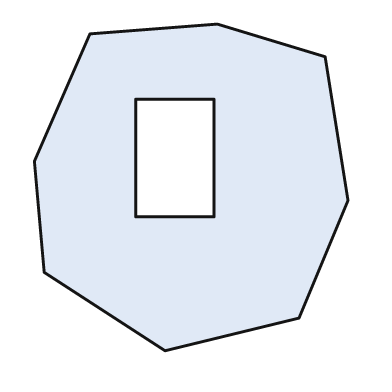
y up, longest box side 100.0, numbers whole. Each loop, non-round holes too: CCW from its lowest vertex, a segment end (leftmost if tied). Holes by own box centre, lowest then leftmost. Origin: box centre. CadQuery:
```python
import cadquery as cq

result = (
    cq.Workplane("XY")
    .moveTo(-8.0, -50.0)
    .lineTo(33.0, -40.0)
    .lineTo(48.0, -4.0)
    .lineTo(41.0, 40.0)
    .lineTo(8.0, 50.0)
    .lineTo(-31.0, 47.0)
    .lineTo(-48.0, 8.0)
    .lineTo(-45.0, -26.0)
    .close()
    .moveTo(-17.0, -9.0)
    .lineTo(7.0, -9.0)
    .lineTo(7.0, 27.0)
    .lineTo(-17.0, 27.0)
    .close()
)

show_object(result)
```